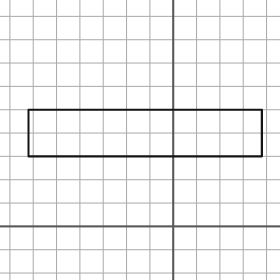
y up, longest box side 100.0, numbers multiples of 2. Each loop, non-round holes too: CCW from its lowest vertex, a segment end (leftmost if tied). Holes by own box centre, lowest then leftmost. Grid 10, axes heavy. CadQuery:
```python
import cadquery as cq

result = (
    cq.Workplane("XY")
    .moveTo(-62.0, 30.0)
    .lineTo(38.0, 30.0)
    .lineTo(38.0, 50.0)
    .lineTo(-62.0, 50.0)
    .close()
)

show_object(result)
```